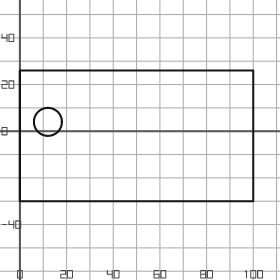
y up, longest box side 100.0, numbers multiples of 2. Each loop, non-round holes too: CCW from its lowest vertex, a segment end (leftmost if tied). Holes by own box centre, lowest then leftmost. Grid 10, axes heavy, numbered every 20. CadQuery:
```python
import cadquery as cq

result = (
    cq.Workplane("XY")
    .moveTo(0.0, -30.0)
    .lineTo(100.0, -30.0)
    .lineTo(100.0, 26.0)
    .lineTo(0.0, 26.0)
    .close()
    .moveTo(12.0, 4.0)
    .circle(6.0)
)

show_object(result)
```